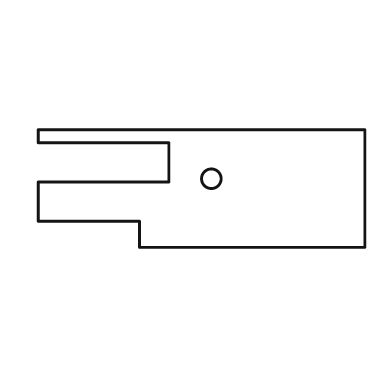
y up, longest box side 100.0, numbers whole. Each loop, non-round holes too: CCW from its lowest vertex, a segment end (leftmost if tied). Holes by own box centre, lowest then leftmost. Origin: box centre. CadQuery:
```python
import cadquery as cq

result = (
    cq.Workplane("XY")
    .moveTo(-19.0, -18.0)
    .lineTo(50.0, -18.0)
    .lineTo(50.0, 18.0)
    .lineTo(-50.0, 18.0)
    .lineTo(-50.0, 14.0)
    .lineTo(-10.0, 14.0)
    .lineTo(-10.0, 2.0)
    .lineTo(-50.0, 2.0)
    .lineTo(-50.0, -10.0)
    .lineTo(-19.0, -10.0)
    .close()
    .moveTo(3.0, 3.0)
    .circle(3.0)
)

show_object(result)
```